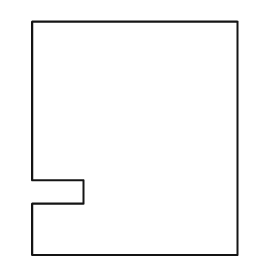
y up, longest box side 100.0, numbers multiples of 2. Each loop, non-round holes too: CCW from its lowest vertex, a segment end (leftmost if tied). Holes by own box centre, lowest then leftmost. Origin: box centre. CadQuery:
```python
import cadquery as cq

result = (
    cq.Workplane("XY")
    .moveTo(-44.0, -50.0)
    .lineTo(44.0, -50.0)
    .lineTo(44.0, 50.0)
    .lineTo(-44.0, 50.0)
    .lineTo(-44.0, -18.0)
    .lineTo(-22.0, -18.0)
    .lineTo(-22.0, -28.0)
    .lineTo(-44.0, -28.0)
    .close()
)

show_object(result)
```